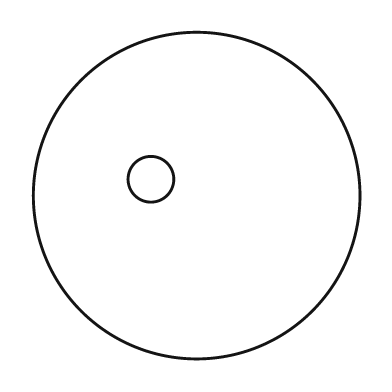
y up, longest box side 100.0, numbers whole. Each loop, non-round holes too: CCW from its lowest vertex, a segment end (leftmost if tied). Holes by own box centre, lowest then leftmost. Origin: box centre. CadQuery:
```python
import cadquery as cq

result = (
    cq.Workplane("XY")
    .moveTo(0.0, 0.0)
    .circle(50.0)
    .moveTo(-14.0, 5.0)
    .circle(7.0)
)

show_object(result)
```